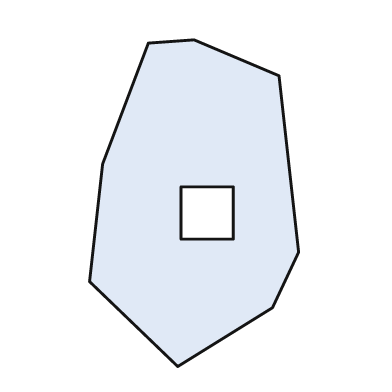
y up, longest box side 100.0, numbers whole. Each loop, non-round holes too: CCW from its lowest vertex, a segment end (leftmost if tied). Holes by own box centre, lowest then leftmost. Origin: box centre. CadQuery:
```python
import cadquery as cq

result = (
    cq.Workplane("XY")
    .moveTo(-5.0, -50.0)
    .lineTo(24.0, -32.0)
    .lineTo(32.0, -15.0)
    .lineTo(26.0, 39.0)
    .lineTo(0.0, 50.0)
    .lineTo(-14.0, 49.0)
    .lineTo(-28.0, 12.0)
    .lineTo(-32.0, -24.0)
    .close()
    .moveTo(-4.0, -11.0)
    .lineTo(12.0, -11.0)
    .lineTo(12.0, 5.0)
    .lineTo(-4.0, 5.0)
    .close()
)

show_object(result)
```